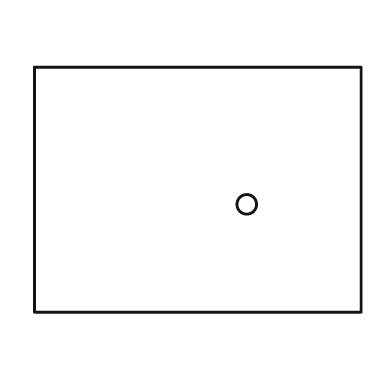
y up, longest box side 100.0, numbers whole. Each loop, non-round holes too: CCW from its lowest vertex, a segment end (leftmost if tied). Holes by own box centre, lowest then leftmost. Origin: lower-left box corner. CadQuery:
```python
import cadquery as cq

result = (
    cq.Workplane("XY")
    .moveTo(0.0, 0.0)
    .lineTo(100.0, 0.0)
    .lineTo(100.0, 75.0)
    .lineTo(0.0, 75.0)
    .close()
    .moveTo(65.0, 33.0)
    .circle(3.0)
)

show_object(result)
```